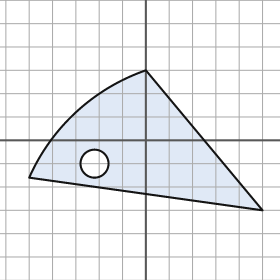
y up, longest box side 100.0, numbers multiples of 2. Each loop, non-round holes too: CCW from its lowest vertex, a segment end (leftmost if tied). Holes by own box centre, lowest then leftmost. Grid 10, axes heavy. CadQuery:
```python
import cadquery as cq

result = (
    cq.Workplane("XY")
    .moveTo(50.0, -30.0)
    .lineTo(0.0, 30.0)
    .threePointArc((-30.0, 12.0), (-50.0, -16.0))
    .close()
    .moveTo(-22.0, -10.0)
    .circle(6.0)
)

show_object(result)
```